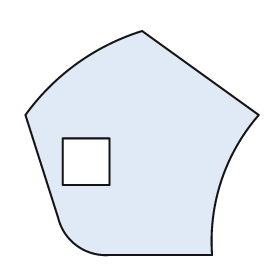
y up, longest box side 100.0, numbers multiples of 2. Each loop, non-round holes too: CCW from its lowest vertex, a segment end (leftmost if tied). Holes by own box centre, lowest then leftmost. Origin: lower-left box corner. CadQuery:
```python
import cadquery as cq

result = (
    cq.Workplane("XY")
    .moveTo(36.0, 0.0)
    .lineTo(80.0, 0.0)
    .threePointArc((84.0, 32.0), (100.0, 60.0))
    .lineTo(50.0, 96.0)
    .threePointArc((22.0, 82.0), (0.0, 60.0))
    .lineTo(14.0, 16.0)
    .threePointArc((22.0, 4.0), (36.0, 0.0))
    .close()
    .moveTo(16.0, 30.0)
    .lineTo(36.0, 30.0)
    .lineTo(36.0, 50.0)
    .lineTo(16.0, 50.0)
    .close()
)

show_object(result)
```